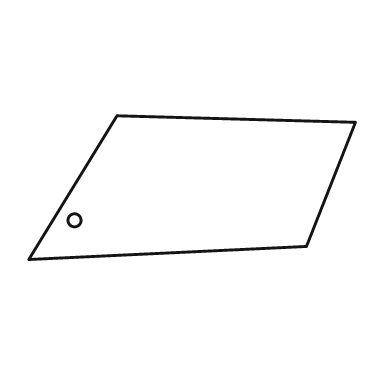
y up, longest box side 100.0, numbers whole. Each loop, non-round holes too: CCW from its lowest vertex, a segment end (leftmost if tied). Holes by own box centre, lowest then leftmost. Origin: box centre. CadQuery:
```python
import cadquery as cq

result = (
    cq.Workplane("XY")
    .moveTo(-50.0, -22.0)
    .lineTo(35.0, -18.0)
    .lineTo(50.0, 20.0)
    .lineTo(-23.0, 22.0)
    .close()
    .moveTo(-36.0, -10.0)
    .circle(2.0)
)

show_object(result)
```